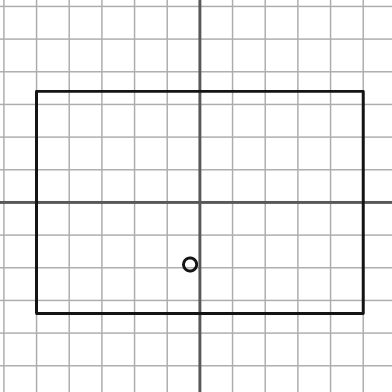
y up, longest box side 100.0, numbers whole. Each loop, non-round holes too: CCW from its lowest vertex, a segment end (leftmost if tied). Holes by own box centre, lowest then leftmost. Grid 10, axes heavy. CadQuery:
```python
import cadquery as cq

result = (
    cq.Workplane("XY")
    .moveTo(-50.0, -34.0)
    .lineTo(50.0, -34.0)
    .lineTo(50.0, 34.0)
    .lineTo(-50.0, 34.0)
    .close()
    .moveTo(-3.0, -19.0)
    .circle(2.0)
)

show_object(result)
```